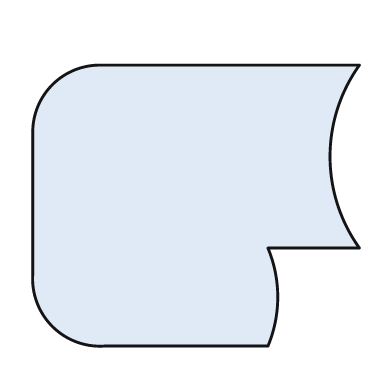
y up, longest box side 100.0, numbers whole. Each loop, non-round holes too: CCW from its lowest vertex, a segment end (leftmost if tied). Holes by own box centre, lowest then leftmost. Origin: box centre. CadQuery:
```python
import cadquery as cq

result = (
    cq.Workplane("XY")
    .moveTo(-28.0, -43.0)
    .lineTo(22.0, -43.0)
    .threePointArc((25.0, -28.0), (22.0, -13.0))
    .lineTo(50.0, -13.0)
    .threePointArc((41.0, 15.0), (50.0, 43.0))
    .lineTo(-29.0, 43.0)
    .threePointArc((-44.0, 37.0), (-50.0, 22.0))
    .lineTo(-50.0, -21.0)
    .threePointArc((-44.0, -37.0), (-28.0, -43.0))
    .close()
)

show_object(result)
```